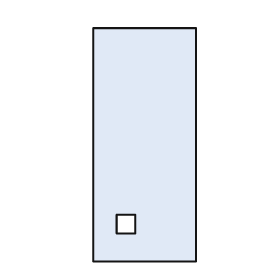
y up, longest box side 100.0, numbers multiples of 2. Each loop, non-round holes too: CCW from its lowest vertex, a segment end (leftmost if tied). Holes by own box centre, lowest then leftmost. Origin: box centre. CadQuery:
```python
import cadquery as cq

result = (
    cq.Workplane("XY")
    .moveTo(-22.0, -50.0)
    .lineTo(22.0, -50.0)
    .lineTo(22.0, 50.0)
    .lineTo(-22.0, 50.0)
    .close()
    .moveTo(-12.0, -38.0)
    .lineTo(-4.0, -38.0)
    .lineTo(-4.0, -30.0)
    .lineTo(-12.0, -30.0)
    .close()
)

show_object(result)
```